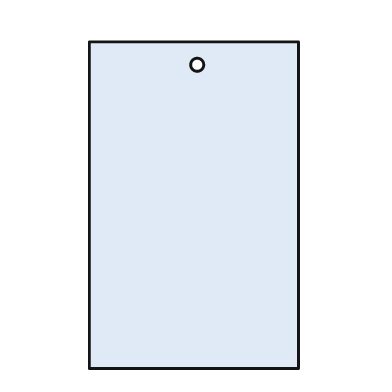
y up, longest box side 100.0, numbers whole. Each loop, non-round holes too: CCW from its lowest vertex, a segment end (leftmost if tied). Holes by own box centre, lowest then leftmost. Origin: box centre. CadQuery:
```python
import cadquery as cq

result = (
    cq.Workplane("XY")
    .moveTo(-32.0, -50.0)
    .lineTo(32.0, -50.0)
    .lineTo(32.0, 50.0)
    .lineTo(-32.0, 50.0)
    .close()
    .moveTo(1.0, 43.0)
    .circle(2.0)
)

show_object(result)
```